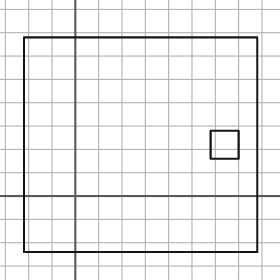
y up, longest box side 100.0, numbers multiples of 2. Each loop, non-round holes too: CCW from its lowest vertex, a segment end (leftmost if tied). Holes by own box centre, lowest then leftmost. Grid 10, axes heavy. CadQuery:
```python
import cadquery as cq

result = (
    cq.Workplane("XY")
    .moveTo(-22.0, -24.0)
    .lineTo(78.0, -24.0)
    .lineTo(78.0, 68.0)
    .lineTo(-22.0, 68.0)
    .close()
    .moveTo(58.0, 16.0)
    .lineTo(70.0, 16.0)
    .lineTo(70.0, 28.0)
    .lineTo(58.0, 28.0)
    .close()
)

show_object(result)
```